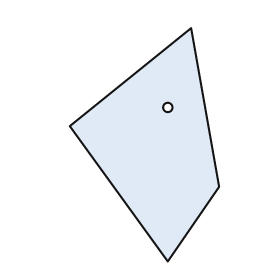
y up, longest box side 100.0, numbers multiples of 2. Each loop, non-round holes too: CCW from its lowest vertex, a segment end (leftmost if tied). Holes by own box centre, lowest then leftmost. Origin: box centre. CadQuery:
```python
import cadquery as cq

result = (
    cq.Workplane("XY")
    .moveTo(10.0, -50.0)
    .lineTo(32.0, -18.0)
    .lineTo(20.0, 50.0)
    .lineTo(-32.0, 8.0)
    .close()
    .moveTo(10.0, 16.0)
    .circle(2.0)
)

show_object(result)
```